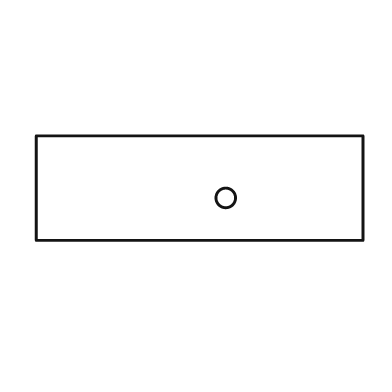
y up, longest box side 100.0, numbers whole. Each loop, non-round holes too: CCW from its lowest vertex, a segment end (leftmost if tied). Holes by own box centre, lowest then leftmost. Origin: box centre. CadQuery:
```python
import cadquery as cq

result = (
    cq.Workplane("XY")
    .moveTo(-50.0, -16.0)
    .lineTo(50.0, -16.0)
    .lineTo(50.0, 16.0)
    .lineTo(-50.0, 16.0)
    .close()
    .moveTo(8.0, -3.0)
    .circle(3.0)
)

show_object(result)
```